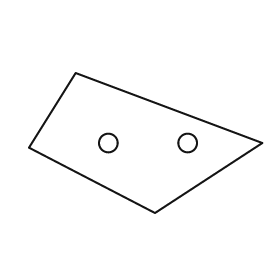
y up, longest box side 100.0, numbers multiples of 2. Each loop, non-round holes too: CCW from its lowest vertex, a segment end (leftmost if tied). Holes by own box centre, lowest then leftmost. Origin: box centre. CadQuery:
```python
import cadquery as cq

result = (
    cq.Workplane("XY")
    .moveTo(4.0, -30.0)
    .lineTo(50.0, 0.0)
    .lineTo(-30.0, 30.0)
    .lineTo(-50.0, -2.0)
    .close()
    .moveTo(-16.0, 0.0)
    .circle(4.0)
    .moveTo(18.0, 0.0)
    .circle(4.0)
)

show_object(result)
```